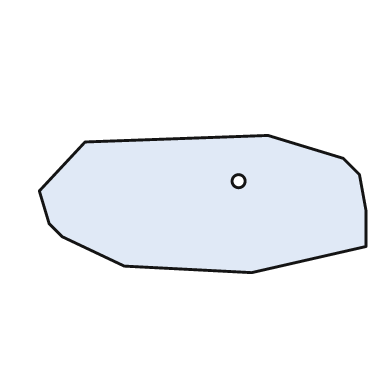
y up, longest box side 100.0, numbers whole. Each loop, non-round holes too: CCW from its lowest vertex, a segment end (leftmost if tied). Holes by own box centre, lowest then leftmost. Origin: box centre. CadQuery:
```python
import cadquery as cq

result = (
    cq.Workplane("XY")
    .moveTo(15.0, -21.0)
    .lineTo(50.0, -13.0)
    .lineTo(50.0, -2.0)
    .lineTo(48.0, 9.0)
    .lineTo(43.0, 14.0)
    .lineTo(20.0, 21.0)
    .lineTo(-36.0, 19.0)
    .lineTo(-50.0, 4.0)
    .lineTo(-47.0, -6.0)
    .lineTo(-43.0, -10.0)
    .lineTo(-24.0, -19.0)
    .close()
    .moveTo(11.0, 7.0)
    .circle(2.0)
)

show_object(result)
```